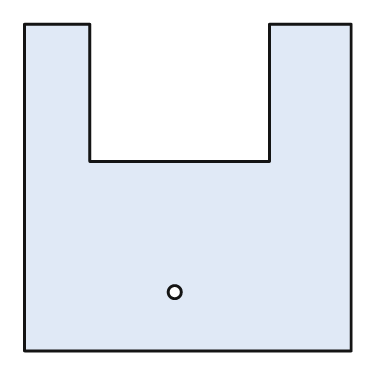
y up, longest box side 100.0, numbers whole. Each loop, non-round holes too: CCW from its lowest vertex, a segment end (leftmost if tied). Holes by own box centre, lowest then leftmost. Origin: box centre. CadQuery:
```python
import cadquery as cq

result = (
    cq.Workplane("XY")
    .moveTo(-50.0, -50.0)
    .lineTo(50.0, -50.0)
    .lineTo(50.0, 50.0)
    .lineTo(25.0, 50.0)
    .lineTo(25.0, 8.0)
    .lineTo(-30.0, 8.0)
    .lineTo(-30.0, 50.0)
    .lineTo(-50.0, 50.0)
    .close()
    .moveTo(-4.0, -32.0)
    .circle(2.0)
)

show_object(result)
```